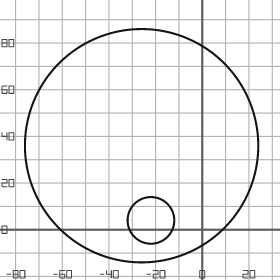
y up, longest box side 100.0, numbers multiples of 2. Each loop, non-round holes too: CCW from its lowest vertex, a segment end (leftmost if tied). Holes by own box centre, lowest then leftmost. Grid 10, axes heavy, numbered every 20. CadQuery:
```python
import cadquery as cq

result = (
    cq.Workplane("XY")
    .moveTo(-26.0, 36.0)
    .circle(50.0)
    .moveTo(-22.0, 4.0)
    .circle(10.0)
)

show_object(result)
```